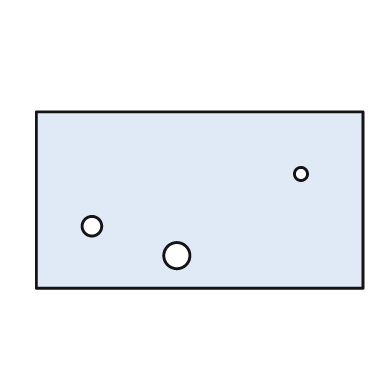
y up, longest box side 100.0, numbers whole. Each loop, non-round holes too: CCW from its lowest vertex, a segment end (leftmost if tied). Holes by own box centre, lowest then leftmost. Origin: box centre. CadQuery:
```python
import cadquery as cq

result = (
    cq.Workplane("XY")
    .moveTo(-50.0, -27.0)
    .lineTo(50.0, -27.0)
    .lineTo(50.0, 27.0)
    .lineTo(-50.0, 27.0)
    .close()
    .moveTo(-7.0, -17.0)
    .circle(4.0)
    .moveTo(-33.0, -8.0)
    .circle(3.0)
    .moveTo(31.0, 8.0)
    .circle(2.0)
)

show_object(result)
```